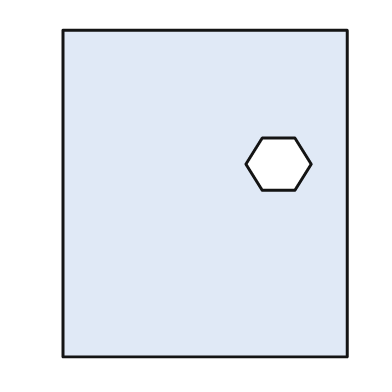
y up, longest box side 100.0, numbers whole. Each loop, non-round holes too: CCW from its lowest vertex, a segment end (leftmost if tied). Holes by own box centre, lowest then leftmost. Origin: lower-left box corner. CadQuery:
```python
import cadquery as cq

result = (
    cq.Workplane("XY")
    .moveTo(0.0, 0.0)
    .lineTo(87.0, 0.0)
    .lineTo(87.0, 100.0)
    .lineTo(0.0, 100.0)
    .close()
    .moveTo(61.0, 51.0)
    .lineTo(71.0, 51.0)
    .lineTo(76.0, 59.0)
    .lineTo(71.0, 67.0)
    .lineTo(61.0, 67.0)
    .lineTo(56.0, 59.0)
    .close()
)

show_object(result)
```